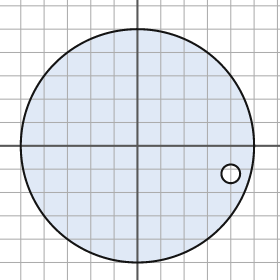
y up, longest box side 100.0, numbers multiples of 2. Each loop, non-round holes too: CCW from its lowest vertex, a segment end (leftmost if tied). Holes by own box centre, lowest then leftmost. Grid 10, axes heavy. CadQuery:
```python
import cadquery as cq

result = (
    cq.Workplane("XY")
    .moveTo(0.0, 0.0)
    .circle(50.0)
    .moveTo(40.0, -12.0)
    .circle(4.0)
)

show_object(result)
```